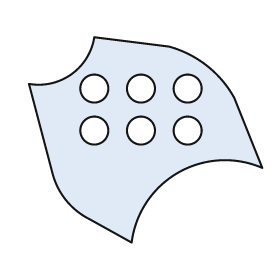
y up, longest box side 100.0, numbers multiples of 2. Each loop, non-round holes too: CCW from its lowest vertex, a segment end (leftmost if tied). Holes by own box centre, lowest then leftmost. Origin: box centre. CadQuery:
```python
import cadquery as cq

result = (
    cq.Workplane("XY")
    .moveTo(-6.0, -44.0)
    .threePointArc((14.0, -14.0), (50.0, -12.0))
    .lineTo(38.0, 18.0)
    .threePointArc((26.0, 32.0), (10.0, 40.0))
    .lineTo(-22.0, 44.0)
    .threePointArc((-32.0, 28.0), (-50.0, 24.0))
    .lineTo(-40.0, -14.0)
    .threePointArc((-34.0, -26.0), (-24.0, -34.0))
    .close()
    .moveTo(-22.0, 4.0)
    .circle(6.0)
    .moveTo(-2.0, 4.0)
    .circle(6.0)
    .moveTo(18.0, 4.0)
    .circle(6.0)
    .moveTo(-22.0, 22.0)
    .circle(6.0)
    .moveTo(-2.0, 22.0)
    .circle(6.0)
    .moveTo(18.0, 22.0)
    .circle(6.0)
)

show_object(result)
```